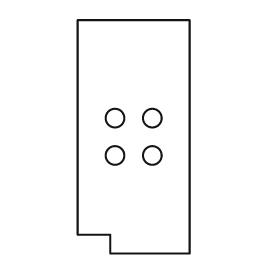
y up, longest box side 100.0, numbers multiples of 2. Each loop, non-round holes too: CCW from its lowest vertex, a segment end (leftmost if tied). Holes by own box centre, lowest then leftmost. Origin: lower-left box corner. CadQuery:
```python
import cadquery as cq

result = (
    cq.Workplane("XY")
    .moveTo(14.0, 0.0)
    .lineTo(48.0, 0.0)
    .lineTo(48.0, 100.0)
    .lineTo(0.0, 100.0)
    .lineTo(0.0, 8.0)
    .lineTo(14.0, 8.0)
    .close()
    .moveTo(16.0, 42.0)
    .circle(4.0)
    .moveTo(32.0, 42.0)
    .circle(4.0)
    .moveTo(16.0, 58.0)
    .circle(4.0)
    .moveTo(32.0, 58.0)
    .circle(4.0)
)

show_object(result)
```